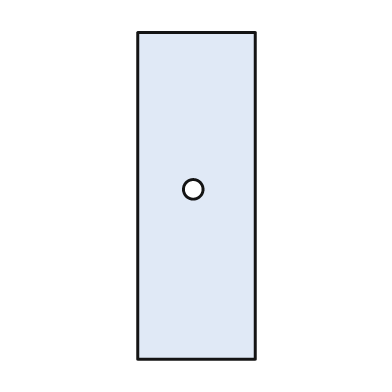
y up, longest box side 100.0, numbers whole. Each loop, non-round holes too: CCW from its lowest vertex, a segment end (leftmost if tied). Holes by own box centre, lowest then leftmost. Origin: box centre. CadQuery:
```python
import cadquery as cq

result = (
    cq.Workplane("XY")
    .moveTo(-18.0, -50.0)
    .lineTo(18.0, -50.0)
    .lineTo(18.0, 50.0)
    .lineTo(-18.0, 50.0)
    .close()
    .moveTo(-1.0, 2.0)
    .circle(3.0)
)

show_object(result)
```